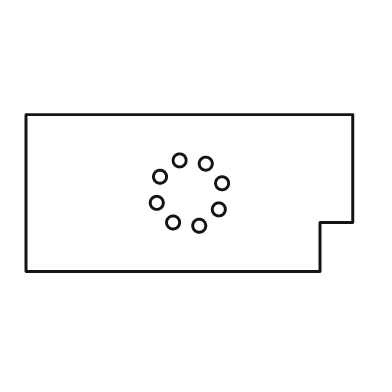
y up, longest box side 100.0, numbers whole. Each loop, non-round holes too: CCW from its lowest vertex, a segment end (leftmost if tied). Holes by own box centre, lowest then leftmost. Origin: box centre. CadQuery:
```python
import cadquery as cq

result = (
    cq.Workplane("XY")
    .moveTo(-50.0, -24.0)
    .lineTo(40.0, -24.0)
    .lineTo(40.0, -9.0)
    .lineTo(50.0, -9.0)
    .lineTo(50.0, 24.0)
    .lineTo(-50.0, 24.0)
    .close()
    .moveTo(3.0, -10.0)
    .circle(2.0)
    .moveTo(-5.0, -9.0)
    .circle(2.0)
    .moveTo(9.0, -5.0)
    .circle(2.0)
    .moveTo(-10.0, -3.0)
    .circle(2.0)
    .moveTo(10.0, 3.0)
    .circle(2.0)
    .moveTo(-9.0, 5.0)
    .circle(2.0)
    .moveTo(5.0, 9.0)
    .circle(2.0)
    .moveTo(-3.0, 10.0)
    .circle(2.0)
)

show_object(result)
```